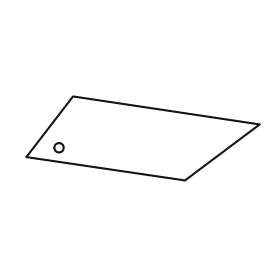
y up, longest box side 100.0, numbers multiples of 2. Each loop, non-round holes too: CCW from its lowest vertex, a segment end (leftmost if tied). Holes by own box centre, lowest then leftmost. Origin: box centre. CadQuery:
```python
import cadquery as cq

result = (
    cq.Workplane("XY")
    .moveTo(18.0, -18.0)
    .lineTo(50.0, 6.0)
    .lineTo(-30.0, 18.0)
    .lineTo(-50.0, -8.0)
    .close()
    .moveTo(-36.0, -4.0)
    .circle(2.0)
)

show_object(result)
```